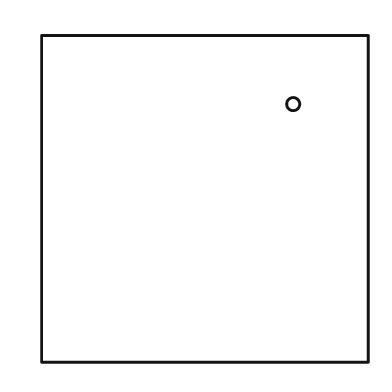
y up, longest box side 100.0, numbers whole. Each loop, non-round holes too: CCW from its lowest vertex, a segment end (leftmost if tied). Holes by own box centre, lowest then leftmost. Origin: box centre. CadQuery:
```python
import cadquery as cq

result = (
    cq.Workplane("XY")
    .moveTo(-50.0, -50.0)
    .lineTo(50.0, -50.0)
    .lineTo(50.0, 50.0)
    .lineTo(-50.0, 50.0)
    .close()
    .moveTo(27.0, 29.0)
    .circle(2.0)
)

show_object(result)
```